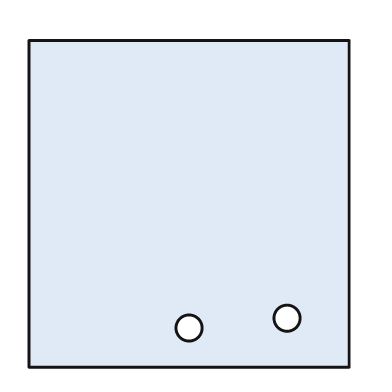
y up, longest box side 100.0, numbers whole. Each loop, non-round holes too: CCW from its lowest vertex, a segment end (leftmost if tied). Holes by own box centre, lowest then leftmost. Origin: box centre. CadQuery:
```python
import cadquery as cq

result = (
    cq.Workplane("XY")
    .moveTo(-49.0, -50.0)
    .lineTo(49.0, -50.0)
    .lineTo(49.0, 50.0)
    .lineTo(-49.0, 50.0)
    .close()
    .moveTo(0.0, -38.0)
    .circle(4.0)
    .moveTo(30.0, -35.0)
    .circle(4.0)
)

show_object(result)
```